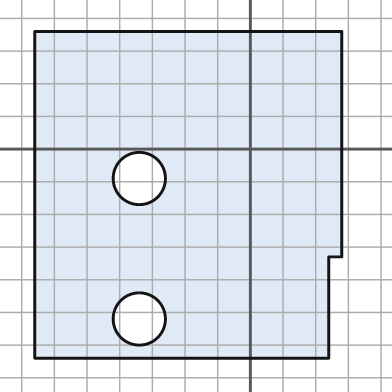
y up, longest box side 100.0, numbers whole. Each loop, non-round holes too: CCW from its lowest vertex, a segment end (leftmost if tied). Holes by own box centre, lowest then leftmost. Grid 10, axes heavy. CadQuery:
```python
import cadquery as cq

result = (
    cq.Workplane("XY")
    .moveTo(-66.0, -64.0)
    .lineTo(24.0, -64.0)
    .lineTo(24.0, -33.0)
    .lineTo(28.0, -33.0)
    .lineTo(28.0, 36.0)
    .lineTo(-66.0, 36.0)
    .close()
    .moveTo(-34.0, -52.0)
    .circle(8.0)
    .moveTo(-34.0, -9.0)
    .circle(8.0)
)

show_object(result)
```